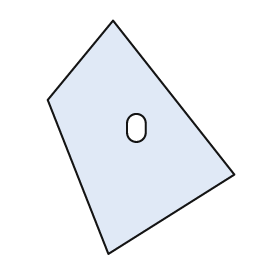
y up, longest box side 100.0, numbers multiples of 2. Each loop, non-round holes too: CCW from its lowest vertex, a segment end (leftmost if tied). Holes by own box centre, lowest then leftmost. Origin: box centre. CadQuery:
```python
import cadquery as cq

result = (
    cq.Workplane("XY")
    .moveTo(-14.0, -50.0)
    .lineTo(40.0, -16.0)
    .lineTo(-12.0, 50.0)
    .lineTo(-40.0, 16.0)
    .close()
    .moveTo(-6.0, 2.0)
    .threePointArc((-2.0, -2.0), (2.0, 2.0))
    .lineTo(2.0, 6.0)
    .threePointArc((-2.0, 10.0), (-6.0, 6.0))
    .close()
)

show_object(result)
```